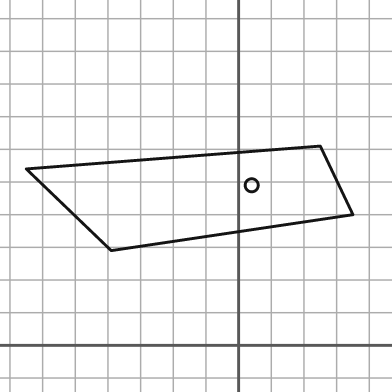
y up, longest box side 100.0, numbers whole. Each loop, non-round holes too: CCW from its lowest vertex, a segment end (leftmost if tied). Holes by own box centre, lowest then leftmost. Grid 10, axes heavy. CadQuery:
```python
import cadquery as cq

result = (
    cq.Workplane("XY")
    .moveTo(-39.0, 29.0)
    .lineTo(35.0, 40.0)
    .lineTo(25.0, 61.0)
    .lineTo(-65.0, 54.0)
    .close()
    .moveTo(4.0, 49.0)
    .circle(2.0)
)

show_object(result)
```